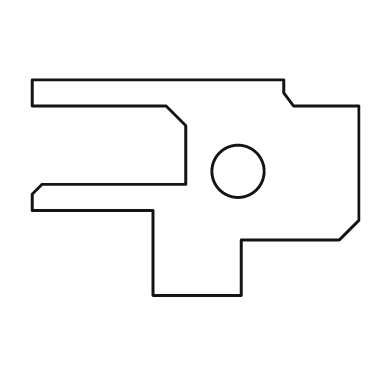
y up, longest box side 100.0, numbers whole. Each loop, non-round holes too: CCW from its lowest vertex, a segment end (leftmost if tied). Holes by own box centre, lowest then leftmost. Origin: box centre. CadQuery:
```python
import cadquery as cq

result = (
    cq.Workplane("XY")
    .moveTo(-13.0, -33.0)
    .lineTo(14.0, -33.0)
    .lineTo(14.0, -16.0)
    .lineTo(44.0, -16.0)
    .lineTo(50.0, -10.0)
    .lineTo(50.0, 25.0)
    .lineTo(30.0, 25.0)
    .lineTo(27.0, 29.0)
    .lineTo(27.0, 33.0)
    .lineTo(-50.0, 33.0)
    .lineTo(-50.0, 25.0)
    .lineTo(-9.0, 25.0)
    .lineTo(-3.0, 19.0)
    .lineTo(-3.0, 1.0)
    .lineTo(-47.0, 1.0)
    .lineTo(-50.0, -2.0)
    .lineTo(-50.0, -7.0)
    .lineTo(-13.0, -7.0)
    .close()
    .moveTo(13.0, 5.0)
    .circle(8.0)
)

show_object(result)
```